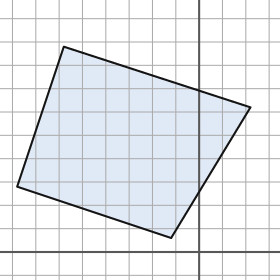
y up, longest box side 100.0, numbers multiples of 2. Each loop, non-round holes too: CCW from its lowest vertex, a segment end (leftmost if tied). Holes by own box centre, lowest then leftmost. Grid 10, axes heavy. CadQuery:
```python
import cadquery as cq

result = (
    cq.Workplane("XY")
    .moveTo(-12.0, 6.0)
    .lineTo(22.0, 62.0)
    .lineTo(-58.0, 88.0)
    .lineTo(-78.0, 28.0)
    .close()
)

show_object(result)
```